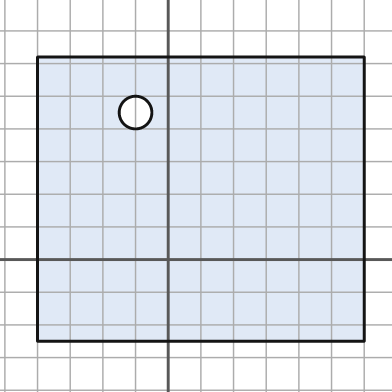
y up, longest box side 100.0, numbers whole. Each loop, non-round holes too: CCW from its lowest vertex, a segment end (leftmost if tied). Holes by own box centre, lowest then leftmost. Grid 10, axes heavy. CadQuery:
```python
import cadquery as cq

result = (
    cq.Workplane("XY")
    .moveTo(-40.0, -25.0)
    .lineTo(60.0, -25.0)
    .lineTo(60.0, 62.0)
    .lineTo(-40.0, 62.0)
    .close()
    .moveTo(-10.0, 45.0)
    .circle(5.0)
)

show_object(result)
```